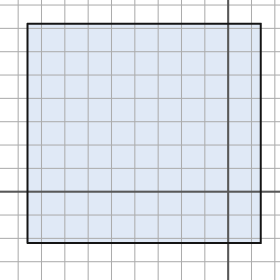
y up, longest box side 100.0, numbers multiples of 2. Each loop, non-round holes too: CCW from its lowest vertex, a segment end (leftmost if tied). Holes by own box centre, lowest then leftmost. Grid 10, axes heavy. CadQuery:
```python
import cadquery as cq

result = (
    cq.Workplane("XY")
    .moveTo(-86.0, -22.0)
    .lineTo(14.0, -22.0)
    .lineTo(14.0, 72.0)
    .lineTo(-86.0, 72.0)
    .close()
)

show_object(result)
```